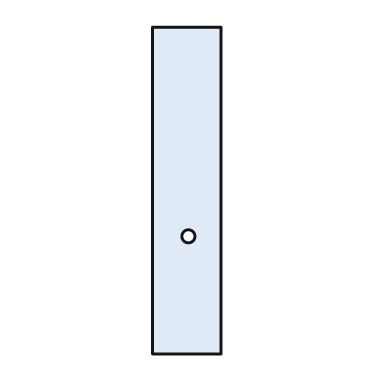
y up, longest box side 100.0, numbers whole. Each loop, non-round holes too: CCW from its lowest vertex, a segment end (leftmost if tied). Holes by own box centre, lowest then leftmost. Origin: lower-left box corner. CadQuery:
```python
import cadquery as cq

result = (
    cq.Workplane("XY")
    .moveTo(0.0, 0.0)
    .lineTo(21.0, 0.0)
    .lineTo(21.0, 100.0)
    .lineTo(0.0, 100.0)
    .close()
    .moveTo(11.0, 36.0)
    .circle(2.0)
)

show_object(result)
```